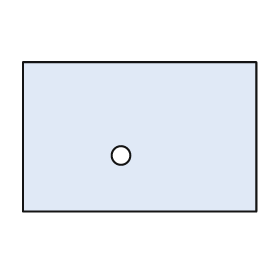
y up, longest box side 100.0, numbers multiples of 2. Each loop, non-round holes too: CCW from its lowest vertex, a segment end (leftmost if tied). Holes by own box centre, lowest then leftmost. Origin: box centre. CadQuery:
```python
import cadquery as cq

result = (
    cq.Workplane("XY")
    .moveTo(-50.0, -32.0)
    .lineTo(50.0, -32.0)
    .lineTo(50.0, 32.0)
    .lineTo(-50.0, 32.0)
    .close()
    .moveTo(-8.0, -8.0)
    .circle(4.0)
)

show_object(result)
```